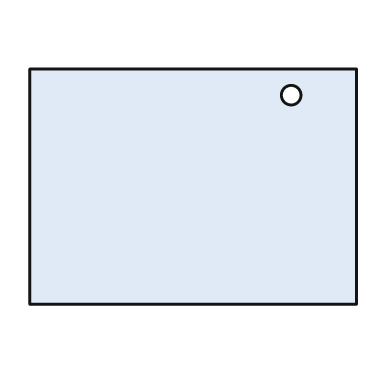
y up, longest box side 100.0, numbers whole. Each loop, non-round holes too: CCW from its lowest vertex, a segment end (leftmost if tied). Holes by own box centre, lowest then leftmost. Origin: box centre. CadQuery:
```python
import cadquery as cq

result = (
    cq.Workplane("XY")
    .moveTo(-50.0, -36.0)
    .lineTo(50.0, -36.0)
    .lineTo(50.0, 36.0)
    .lineTo(-50.0, 36.0)
    .close()
    .moveTo(30.0, 28.0)
    .circle(3.0)
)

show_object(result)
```